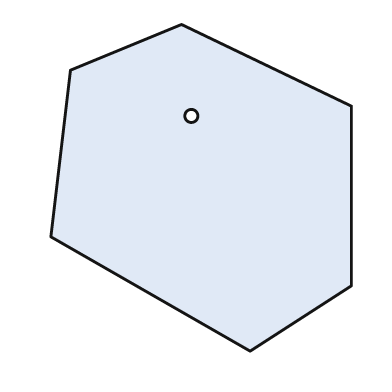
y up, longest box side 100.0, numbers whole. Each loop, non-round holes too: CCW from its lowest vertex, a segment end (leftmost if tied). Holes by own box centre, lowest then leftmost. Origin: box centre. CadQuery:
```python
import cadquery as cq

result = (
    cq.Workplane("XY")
    .moveTo(15.0, -50.0)
    .lineTo(46.0, -30.0)
    .lineTo(46.0, 25.0)
    .lineTo(-6.0, 50.0)
    .lineTo(-40.0, 36.0)
    .lineTo(-46.0, -15.0)
    .close()
    .moveTo(-3.0, 22.0)
    .circle(2.0)
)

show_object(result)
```